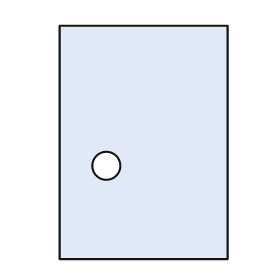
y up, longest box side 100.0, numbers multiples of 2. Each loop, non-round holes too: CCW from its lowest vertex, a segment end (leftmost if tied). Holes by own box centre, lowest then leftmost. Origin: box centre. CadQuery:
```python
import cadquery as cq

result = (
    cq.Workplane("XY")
    .moveTo(-36.0, -50.0)
    .lineTo(36.0, -50.0)
    .lineTo(36.0, 50.0)
    .lineTo(-36.0, 50.0)
    .close()
    .moveTo(-16.0, -10.0)
    .circle(6.0)
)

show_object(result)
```